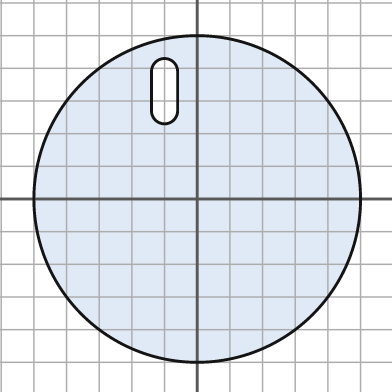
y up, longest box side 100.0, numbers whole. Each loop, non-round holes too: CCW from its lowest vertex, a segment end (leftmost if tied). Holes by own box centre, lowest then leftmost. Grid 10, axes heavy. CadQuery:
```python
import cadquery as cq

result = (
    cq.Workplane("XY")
    .moveTo(0.0, 0.0)
    .circle(50.0)
    .moveTo(-14.0, 27.0)
    .threePointArc((-10.0, 23.0), (-6.0, 27.0))
    .lineTo(-6.0, 39.0)
    .threePointArc((-10.0, 43.0), (-14.0, 39.0))
    .close()
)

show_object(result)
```